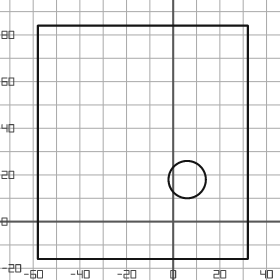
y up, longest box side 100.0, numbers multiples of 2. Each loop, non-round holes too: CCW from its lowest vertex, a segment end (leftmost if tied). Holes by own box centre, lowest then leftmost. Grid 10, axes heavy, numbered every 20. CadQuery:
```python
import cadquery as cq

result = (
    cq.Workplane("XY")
    .moveTo(-58.0, -16.0)
    .lineTo(32.0, -16.0)
    .lineTo(32.0, 84.0)
    .lineTo(-58.0, 84.0)
    .close()
    .moveTo(6.0, 18.0)
    .circle(8.0)
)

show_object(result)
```